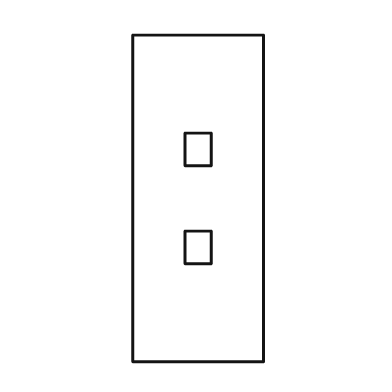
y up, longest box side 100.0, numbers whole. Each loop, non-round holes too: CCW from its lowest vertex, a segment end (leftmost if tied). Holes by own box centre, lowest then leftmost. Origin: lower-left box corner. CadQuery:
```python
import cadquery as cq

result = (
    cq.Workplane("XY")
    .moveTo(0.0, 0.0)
    .lineTo(40.0, 0.0)
    .lineTo(40.0, 100.0)
    .lineTo(0.0, 100.0)
    .close()
    .moveTo(16.0, 30.0)
    .lineTo(24.0, 30.0)
    .lineTo(24.0, 40.0)
    .lineTo(16.0, 40.0)
    .close()
    .moveTo(16.0, 60.0)
    .lineTo(24.0, 60.0)
    .lineTo(24.0, 70.0)
    .lineTo(16.0, 70.0)
    .close()
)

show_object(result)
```